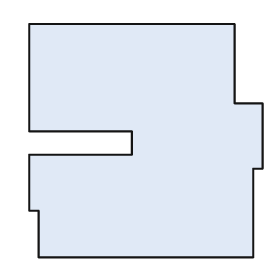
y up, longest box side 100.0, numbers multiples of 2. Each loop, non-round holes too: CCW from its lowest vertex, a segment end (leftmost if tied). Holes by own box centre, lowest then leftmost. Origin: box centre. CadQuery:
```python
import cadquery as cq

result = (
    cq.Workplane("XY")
    .moveTo(-46.0, -50.0)
    .lineTo(46.0, -50.0)
    .lineTo(46.0, -12.0)
    .lineTo(50.0, -12.0)
    .lineTo(50.0, 16.0)
    .lineTo(38.0, 16.0)
    .lineTo(38.0, 50.0)
    .lineTo(-50.0, 50.0)
    .lineTo(-50.0, 4.0)
    .lineTo(-6.0, 4.0)
    .lineTo(-6.0, -6.0)
    .lineTo(-50.0, -6.0)
    .lineTo(-50.0, -30.0)
    .lineTo(-46.0, -30.0)
    .close()
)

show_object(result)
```